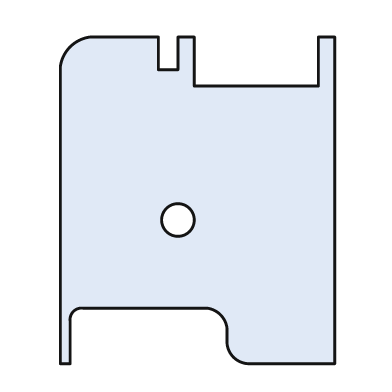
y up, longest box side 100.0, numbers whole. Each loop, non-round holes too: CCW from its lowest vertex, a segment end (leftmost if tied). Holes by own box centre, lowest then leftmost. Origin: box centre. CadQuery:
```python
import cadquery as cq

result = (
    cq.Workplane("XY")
    .moveTo(-42.0, -50.0)
    .lineTo(-39.0, -50.0)
    .lineTo(-39.0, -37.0)
    .threePointArc((-38.0, -34.0), (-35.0, -33.0))
    .lineTo(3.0, -33.0)
    .threePointArc((7.0, -35.0), (9.0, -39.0))
    .lineTo(9.0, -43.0)
    .threePointArc((11.0, -48.0), (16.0, -50.0))
    .lineTo(42.0, -50.0)
    .lineTo(42.0, 50.0)
    .lineTo(37.0, 50.0)
    .lineTo(37.0, 35.0)
    .lineTo(-1.0, 35.0)
    .lineTo(-1.0, 50.0)
    .lineTo(-6.0, 50.0)
    .lineTo(-6.0, 40.0)
    .lineTo(-12.0, 40.0)
    .lineTo(-12.0, 50.0)
    .lineTo(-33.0, 50.0)
    .threePointArc((-39.0, 47.0), (-42.0, 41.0))
    .close()
    .moveTo(-6.0, -6.0)
    .circle(5.0)
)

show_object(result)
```